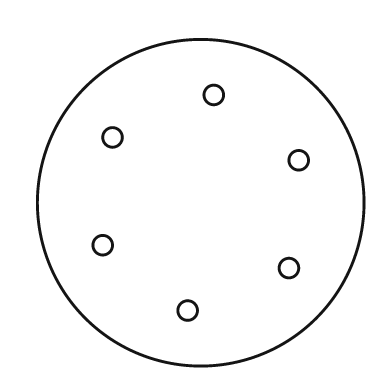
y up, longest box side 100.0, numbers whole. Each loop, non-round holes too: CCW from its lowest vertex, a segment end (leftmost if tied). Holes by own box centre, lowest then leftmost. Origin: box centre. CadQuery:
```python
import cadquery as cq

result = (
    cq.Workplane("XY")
    .moveTo(0.0, 0.0)
    .circle(50.0)
    .moveTo(-4.0, -33.0)
    .circle(3.0)
    .moveTo(27.0, -20.0)
    .circle(3.0)
    .moveTo(-30.0, -13.0)
    .circle(3.0)
    .moveTo(30.0, 13.0)
    .circle(3.0)
    .moveTo(-27.0, 20.0)
    .circle(3.0)
    .moveTo(4.0, 33.0)
    .circle(3.0)
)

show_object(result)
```